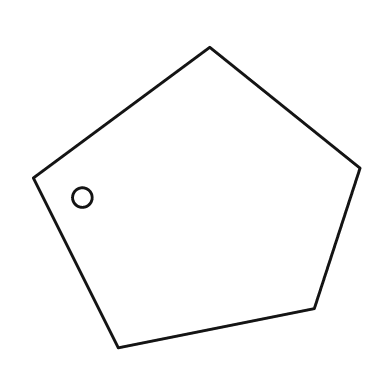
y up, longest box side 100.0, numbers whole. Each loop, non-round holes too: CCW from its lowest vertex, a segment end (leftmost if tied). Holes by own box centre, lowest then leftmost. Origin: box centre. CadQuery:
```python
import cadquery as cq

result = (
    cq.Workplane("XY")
    .moveTo(-24.0, -46.0)
    .lineTo(36.0, -34.0)
    .lineTo(50.0, 9.0)
    .lineTo(4.0, 46.0)
    .lineTo(-50.0, 6.0)
    .close()
    .moveTo(-35.0, 0.0)
    .circle(3.0)
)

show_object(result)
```